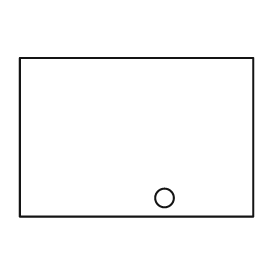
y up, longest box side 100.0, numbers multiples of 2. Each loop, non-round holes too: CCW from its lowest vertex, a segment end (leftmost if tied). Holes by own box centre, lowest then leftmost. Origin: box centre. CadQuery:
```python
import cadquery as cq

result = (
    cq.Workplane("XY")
    .moveTo(-50.0, -34.0)
    .lineTo(50.0, -34.0)
    .lineTo(50.0, 34.0)
    .lineTo(-50.0, 34.0)
    .close()
    .moveTo(12.0, -26.0)
    .circle(4.0)
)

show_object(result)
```